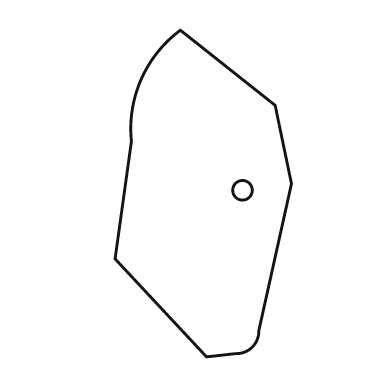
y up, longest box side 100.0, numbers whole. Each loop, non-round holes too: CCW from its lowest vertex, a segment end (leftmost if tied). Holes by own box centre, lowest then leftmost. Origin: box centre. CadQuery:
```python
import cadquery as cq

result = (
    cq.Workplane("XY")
    .moveTo(1.0, -50.0)
    .lineTo(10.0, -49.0)
    .threePointArc((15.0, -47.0), (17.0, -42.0))
    .lineTo(27.0, 3.0)
    .lineTo(22.0, 27.0)
    .lineTo(-7.0, 50.0)
    .threePointArc((-19.0, 35.0), (-22.0, 16.0))
    .lineTo(-27.0, -20.0)
    .close()
    .moveTo(12.0, 1.0)
    .circle(3.0)
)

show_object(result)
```